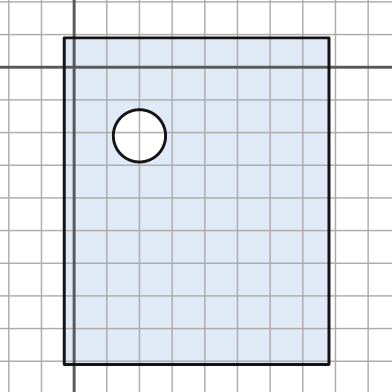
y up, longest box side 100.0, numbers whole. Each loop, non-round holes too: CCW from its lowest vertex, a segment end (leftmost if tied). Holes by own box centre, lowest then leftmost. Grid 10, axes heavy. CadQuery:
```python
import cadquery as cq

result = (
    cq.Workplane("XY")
    .moveTo(-3.0, -91.0)
    .lineTo(78.0, -91.0)
    .lineTo(78.0, 9.0)
    .lineTo(-3.0, 9.0)
    .close()
    .moveTo(20.0, -21.0)
    .circle(8.0)
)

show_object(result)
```